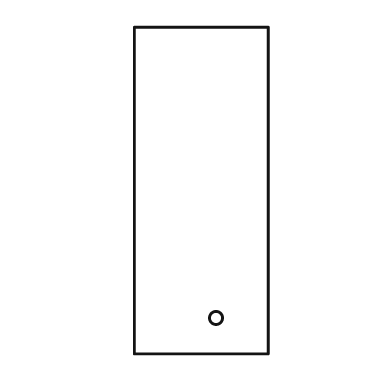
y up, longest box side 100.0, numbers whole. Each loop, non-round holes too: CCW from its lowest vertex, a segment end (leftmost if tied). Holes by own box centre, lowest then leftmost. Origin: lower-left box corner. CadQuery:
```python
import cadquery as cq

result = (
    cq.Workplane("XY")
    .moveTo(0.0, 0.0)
    .lineTo(41.0, 0.0)
    .lineTo(41.0, 100.0)
    .lineTo(0.0, 100.0)
    .close()
    .moveTo(25.0, 11.0)
    .circle(2.0)
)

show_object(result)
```